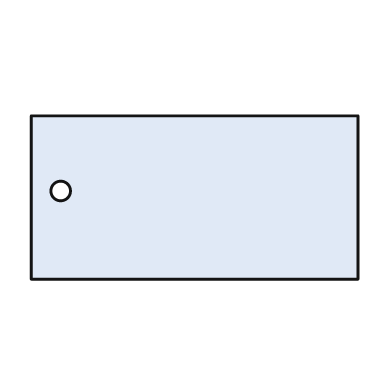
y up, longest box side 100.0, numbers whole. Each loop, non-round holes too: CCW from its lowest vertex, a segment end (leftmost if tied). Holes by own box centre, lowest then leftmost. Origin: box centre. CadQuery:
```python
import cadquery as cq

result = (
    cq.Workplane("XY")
    .moveTo(-50.0, -25.0)
    .lineTo(50.0, -25.0)
    .lineTo(50.0, 25.0)
    .lineTo(-50.0, 25.0)
    .close()
    .moveTo(-41.0, 2.0)
    .circle(3.0)
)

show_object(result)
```